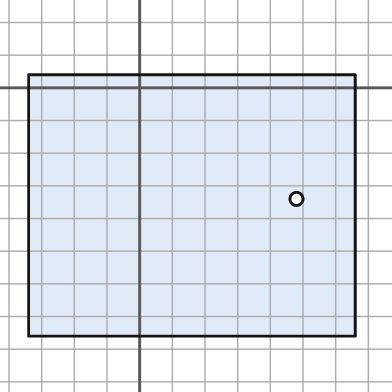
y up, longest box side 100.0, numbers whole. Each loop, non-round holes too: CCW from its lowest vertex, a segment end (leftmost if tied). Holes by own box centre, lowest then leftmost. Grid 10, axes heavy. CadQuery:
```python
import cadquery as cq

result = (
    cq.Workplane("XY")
    .moveTo(-34.0, -76.0)
    .lineTo(66.0, -76.0)
    .lineTo(66.0, 4.0)
    .lineTo(-34.0, 4.0)
    .close()
    .moveTo(48.0, -34.0)
    .circle(2.0)
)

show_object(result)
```